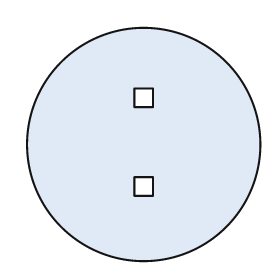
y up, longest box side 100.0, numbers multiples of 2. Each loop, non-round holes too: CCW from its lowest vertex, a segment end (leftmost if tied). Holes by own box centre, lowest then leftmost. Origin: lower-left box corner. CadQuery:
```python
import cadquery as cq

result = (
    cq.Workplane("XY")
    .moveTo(50.0, 50.0)
    .circle(50.0)
    .moveTo(46.0, 28.0)
    .lineTo(54.0, 28.0)
    .lineTo(54.0, 36.0)
    .lineTo(46.0, 36.0)
    .close()
    .moveTo(46.0, 66.0)
    .lineTo(54.0, 66.0)
    .lineTo(54.0, 74.0)
    .lineTo(46.0, 74.0)
    .close()
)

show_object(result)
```